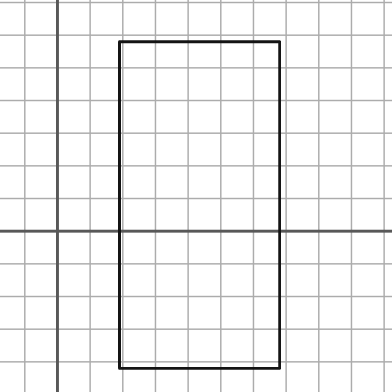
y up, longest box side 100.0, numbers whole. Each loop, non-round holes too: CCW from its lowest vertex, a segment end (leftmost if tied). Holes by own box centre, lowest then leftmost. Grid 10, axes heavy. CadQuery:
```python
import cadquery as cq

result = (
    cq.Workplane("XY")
    .moveTo(19.0, -42.0)
    .lineTo(68.0, -42.0)
    .lineTo(68.0, 58.0)
    .lineTo(19.0, 58.0)
    .close()
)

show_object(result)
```